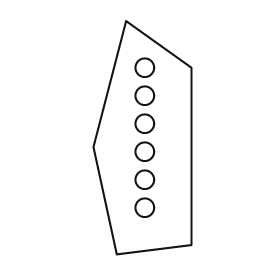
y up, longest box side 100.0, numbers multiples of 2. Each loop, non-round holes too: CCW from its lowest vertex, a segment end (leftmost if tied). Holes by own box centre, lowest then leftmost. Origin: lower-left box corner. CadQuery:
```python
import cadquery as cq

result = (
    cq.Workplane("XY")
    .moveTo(10.0, 0.0)
    .lineTo(42.0, 4.0)
    .lineTo(42.0, 80.0)
    .lineTo(14.0, 100.0)
    .lineTo(0.0, 46.0)
    .close()
    .moveTo(22.0, 20.0)
    .circle(4.0)
    .moveTo(22.0, 32.0)
    .circle(4.0)
    .moveTo(22.0, 44.0)
    .circle(4.0)
    .moveTo(22.0, 56.0)
    .circle(4.0)
    .moveTo(22.0, 68.0)
    .circle(4.0)
    .moveTo(22.0, 80.0)
    .circle(4.0)
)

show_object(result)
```